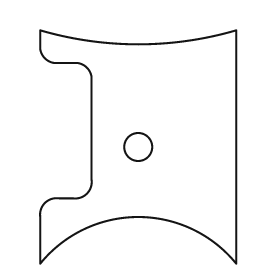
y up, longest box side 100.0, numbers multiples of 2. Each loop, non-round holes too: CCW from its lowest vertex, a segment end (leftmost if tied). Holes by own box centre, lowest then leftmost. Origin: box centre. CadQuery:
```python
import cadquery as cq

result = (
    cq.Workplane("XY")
    .moveTo(-42.0, -50.0)
    .threePointArc((0.0, -30.0), (42.0, -50.0))
    .lineTo(42.0, 50.0)
    .threePointArc((0.0, 44.0), (-42.0, 50.0))
    .lineTo(-42.0, 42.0)
    .threePointArc((-40.0, 38.0), (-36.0, 36.0))
    .lineTo(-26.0, 36.0)
    .threePointArc((-22.0, 34.0), (-20.0, 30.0))
    .lineTo(-20.0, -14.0)
    .threePointArc((-22.0, -20.0), (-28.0, -22.0))
    .lineTo(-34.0, -22.0)
    .threePointArc((-40.0, -24.0), (-42.0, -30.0))
    .close()
    .moveTo(0.0, 0.0)
    .circle(6.0)
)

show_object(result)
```